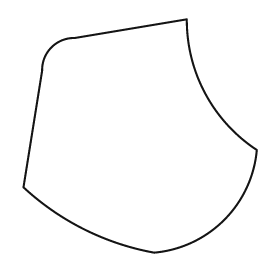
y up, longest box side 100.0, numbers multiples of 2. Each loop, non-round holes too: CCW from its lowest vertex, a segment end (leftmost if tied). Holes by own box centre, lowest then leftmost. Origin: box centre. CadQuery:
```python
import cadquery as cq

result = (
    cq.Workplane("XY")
    .moveTo(6.0, -50.0)
    .threePointArc((36.0, -36.0), (50.0, -6.0))
    .threePointArc((28.0, 18.0), (20.0, 50.0))
    .lineTo(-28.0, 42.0)
    .threePointArc((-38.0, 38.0), (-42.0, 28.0))
    .lineTo(-50.0, -22.0)
    .threePointArc((-24.0, -40.0), (6.0, -50.0))
    .close()
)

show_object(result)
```